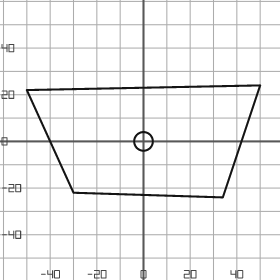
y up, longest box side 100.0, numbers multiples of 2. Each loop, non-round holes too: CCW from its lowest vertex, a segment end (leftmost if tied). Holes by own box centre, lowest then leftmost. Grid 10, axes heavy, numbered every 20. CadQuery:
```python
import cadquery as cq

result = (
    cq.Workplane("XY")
    .moveTo(34.0, -24.0)
    .lineTo(50.0, 24.0)
    .lineTo(-50.0, 22.0)
    .lineTo(-30.0, -22.0)
    .close()
    .moveTo(0.0, 0.0)
    .circle(4.0)
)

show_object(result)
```